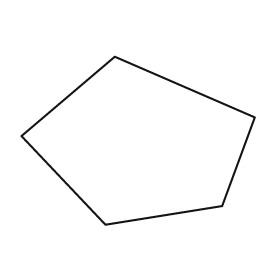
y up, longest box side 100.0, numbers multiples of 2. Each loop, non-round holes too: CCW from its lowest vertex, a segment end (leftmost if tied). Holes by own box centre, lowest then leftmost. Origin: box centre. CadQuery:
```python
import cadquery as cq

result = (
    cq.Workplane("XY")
    .moveTo(-14.0, -36.0)
    .lineTo(36.0, -28.0)
    .lineTo(50.0, 10.0)
    .lineTo(-10.0, 36.0)
    .lineTo(-50.0, 2.0)
    .close()
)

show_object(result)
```